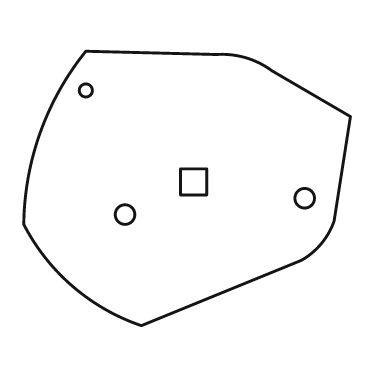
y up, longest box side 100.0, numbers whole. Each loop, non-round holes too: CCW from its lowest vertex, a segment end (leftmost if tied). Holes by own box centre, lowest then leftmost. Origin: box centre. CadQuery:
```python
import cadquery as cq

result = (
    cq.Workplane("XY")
    .moveTo(-14.0, -42.0)
    .lineTo(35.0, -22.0)
    .threePointArc((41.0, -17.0), (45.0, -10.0))
    .lineTo(50.0, 22.0)
    .lineTo(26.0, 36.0)
    .threePointArc((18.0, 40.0), (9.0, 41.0))
    .lineTo(-31.0, 42.0)
    .threePointArc((-45.0, 17.0), (-50.0, -11.0))
    .threePointArc((-35.0, -30.0), (-14.0, -42.0))
    .close()
    .moveTo(-19.0, -8.0)
    .circle(3.0)
    .moveTo(36.0, -3.0)
    .circle(3.0)
    .moveTo(-2.0, -2.0)
    .lineTo(6.0, -2.0)
    .lineTo(6.0, 6.0)
    .lineTo(-2.0, 6.0)
    .close()
    .moveTo(-31.0, 30.0)
    .circle(2.0)
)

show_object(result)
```